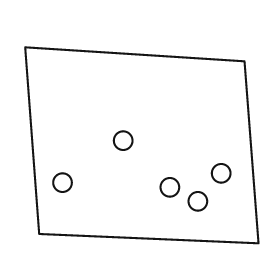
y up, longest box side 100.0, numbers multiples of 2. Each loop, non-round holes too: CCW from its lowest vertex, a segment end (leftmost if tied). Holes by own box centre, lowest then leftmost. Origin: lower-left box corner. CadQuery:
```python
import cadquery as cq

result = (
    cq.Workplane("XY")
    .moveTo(100.0, 0.0)
    .lineTo(94.0, 78.0)
    .lineTo(0.0, 84.0)
    .lineTo(6.0, 4.0)
    .close()
    .moveTo(74.0, 18.0)
    .circle(4.0)
    .moveTo(62.0, 24.0)
    .circle(4.0)
    .moveTo(16.0, 26.0)
    .circle(4.0)
    .moveTo(84.0, 30.0)
    .circle(4.0)
    .moveTo(42.0, 44.0)
    .circle(4.0)
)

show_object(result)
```